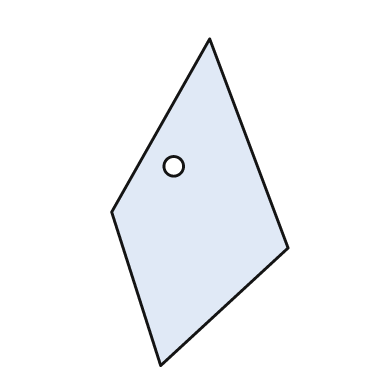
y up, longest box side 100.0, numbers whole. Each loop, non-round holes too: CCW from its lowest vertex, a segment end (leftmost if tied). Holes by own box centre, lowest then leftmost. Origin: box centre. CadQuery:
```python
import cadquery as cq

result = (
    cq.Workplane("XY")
    .moveTo(-12.0, -50.0)
    .lineTo(27.0, -14.0)
    .lineTo(3.0, 50.0)
    .lineTo(-27.0, -3.0)
    .close()
    .moveTo(-8.0, 11.0)
    .circle(3.0)
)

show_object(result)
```